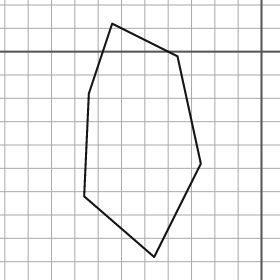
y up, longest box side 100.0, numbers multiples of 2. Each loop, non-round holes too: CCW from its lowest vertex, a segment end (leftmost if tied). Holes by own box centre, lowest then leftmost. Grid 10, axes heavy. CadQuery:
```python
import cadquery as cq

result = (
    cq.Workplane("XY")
    .moveTo(-46.0, -88.0)
    .lineTo(-26.0, -48.0)
    .lineTo(-36.0, -2.0)
    .lineTo(-64.0, 12.0)
    .lineTo(-74.0, -18.0)
    .lineTo(-76.0, -62.0)
    .close()
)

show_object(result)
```